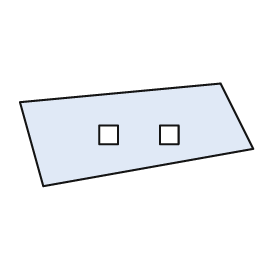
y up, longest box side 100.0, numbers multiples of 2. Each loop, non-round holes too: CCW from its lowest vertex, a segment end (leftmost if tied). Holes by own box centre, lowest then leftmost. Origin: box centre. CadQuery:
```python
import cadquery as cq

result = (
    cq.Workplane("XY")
    .moveTo(-40.0, -22.0)
    .lineTo(50.0, -6.0)
    .lineTo(36.0, 22.0)
    .lineTo(-50.0, 14.0)
    .close()
    .moveTo(-16.0, -4.0)
    .lineTo(-8.0, -4.0)
    .lineTo(-8.0, 4.0)
    .lineTo(-16.0, 4.0)
    .close()
    .moveTo(10.0, -4.0)
    .lineTo(18.0, -4.0)
    .lineTo(18.0, 4.0)
    .lineTo(10.0, 4.0)
    .close()
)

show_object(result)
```